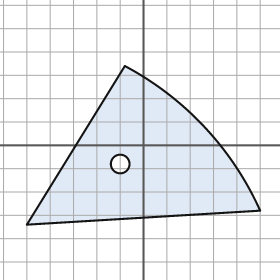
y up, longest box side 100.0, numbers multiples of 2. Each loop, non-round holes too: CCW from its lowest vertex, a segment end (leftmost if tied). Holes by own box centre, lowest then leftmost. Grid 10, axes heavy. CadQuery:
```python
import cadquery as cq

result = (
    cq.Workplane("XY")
    .moveTo(-50.0, -34.0)
    .lineTo(50.0, -28.0)
    .threePointArc((26.0, 8.0), (-8.0, 34.0))
    .close()
    .moveTo(-10.0, -8.0)
    .circle(4.0)
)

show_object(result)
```